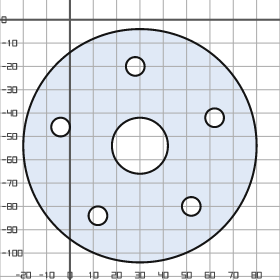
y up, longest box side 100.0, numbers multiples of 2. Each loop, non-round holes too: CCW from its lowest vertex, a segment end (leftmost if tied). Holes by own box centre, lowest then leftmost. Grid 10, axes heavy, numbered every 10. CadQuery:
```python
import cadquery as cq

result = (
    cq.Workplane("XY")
    .moveTo(30.0, -54.0)
    .circle(50.0)
    .moveTo(12.0, -84.0)
    .circle(4.0)
    .moveTo(52.0, -80.0)
    .circle(4.0)
    .moveTo(30.0, -54.0)
    .circle(12.0)
    .moveTo(-4.0, -46.0)
    .circle(4.0)
    .moveTo(62.0, -42.0)
    .circle(4.0)
    .moveTo(28.0, -20.0)
    .circle(4.0)
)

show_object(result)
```